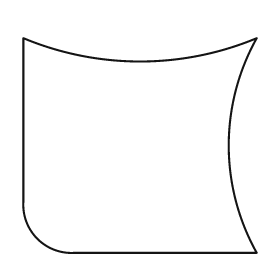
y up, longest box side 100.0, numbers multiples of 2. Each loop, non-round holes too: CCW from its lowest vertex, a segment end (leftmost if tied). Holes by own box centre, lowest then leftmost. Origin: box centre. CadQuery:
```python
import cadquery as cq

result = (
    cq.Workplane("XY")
    .moveTo(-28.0, -46.0)
    .lineTo(50.0, -46.0)
    .threePointArc((38.0, 0.0), (50.0, 46.0))
    .threePointArc((0.0, 36.0), (-50.0, 46.0))
    .lineTo(-50.0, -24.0)
    .threePointArc((-44.0, -40.0), (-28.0, -46.0))
    .close()
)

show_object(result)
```